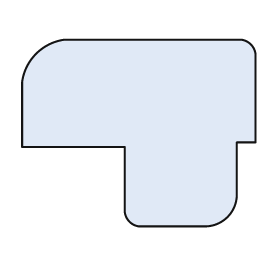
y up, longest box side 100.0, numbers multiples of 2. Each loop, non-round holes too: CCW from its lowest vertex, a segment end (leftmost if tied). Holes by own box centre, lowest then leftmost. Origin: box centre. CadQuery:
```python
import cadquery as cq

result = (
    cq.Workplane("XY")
    .moveTo(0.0, -40.0)
    .lineTo(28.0, -40.0)
    .threePointArc((38.0, -36.0), (42.0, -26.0))
    .lineTo(42.0, -4.0)
    .lineTo(50.0, -4.0)
    .lineTo(50.0, 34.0)
    .threePointArc((48.0, 38.0), (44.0, 40.0))
    .lineTo(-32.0, 40.0)
    .threePointArc((-44.0, 34.0), (-50.0, 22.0))
    .lineTo(-50.0, -6.0)
    .lineTo(-6.0, -6.0)
    .lineTo(-6.0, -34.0)
    .threePointArc((-4.0, -38.0), (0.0, -40.0))
    .close()
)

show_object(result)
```